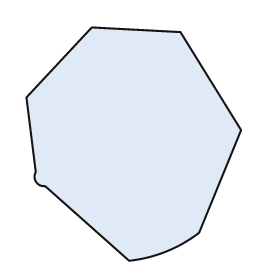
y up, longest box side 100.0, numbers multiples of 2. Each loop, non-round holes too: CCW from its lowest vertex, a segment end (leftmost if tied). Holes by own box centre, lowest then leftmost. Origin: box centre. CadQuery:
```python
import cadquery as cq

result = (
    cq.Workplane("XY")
    .moveTo(-2.0, -50.0)
    .threePointArc((14.0, -46.0), (28.0, -38.0))
    .lineTo(46.0, 6.0)
    .lineTo(20.0, 48.0)
    .lineTo(-18.0, 50.0)
    .lineTo(-46.0, 20.0)
    .lineTo(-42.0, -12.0)
    .threePointArc((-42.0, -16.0), (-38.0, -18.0))
    .close()
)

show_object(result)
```